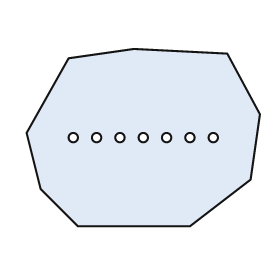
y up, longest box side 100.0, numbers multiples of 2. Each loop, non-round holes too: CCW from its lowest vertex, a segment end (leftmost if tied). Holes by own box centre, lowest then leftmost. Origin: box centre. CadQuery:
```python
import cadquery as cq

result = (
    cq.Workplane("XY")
    .moveTo(-28.0, -38.0)
    .lineTo(20.0, -38.0)
    .lineTo(46.0, -18.0)
    .lineTo(50.0, 10.0)
    .lineTo(36.0, 36.0)
    .lineTo(-4.0, 38.0)
    .lineTo(-32.0, 34.0)
    .lineTo(-50.0, 2.0)
    .lineTo(-44.0, -22.0)
    .close()
    .moveTo(-30.0, 0.0)
    .circle(2.0)
    .moveTo(-20.0, 0.0)
    .circle(2.0)
    .moveTo(-10.0, 0.0)
    .circle(2.0)
    .moveTo(0.0, 0.0)
    .circle(2.0)
    .moveTo(10.0, 0.0)
    .circle(2.0)
    .moveTo(20.0, 0.0)
    .circle(2.0)
    .moveTo(30.0, 0.0)
    .circle(2.0)
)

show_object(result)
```